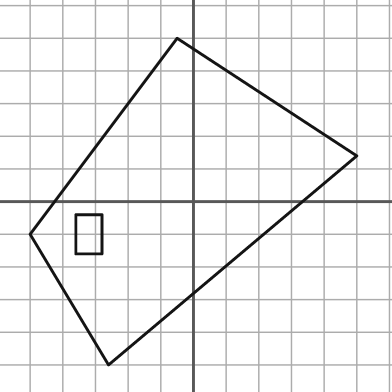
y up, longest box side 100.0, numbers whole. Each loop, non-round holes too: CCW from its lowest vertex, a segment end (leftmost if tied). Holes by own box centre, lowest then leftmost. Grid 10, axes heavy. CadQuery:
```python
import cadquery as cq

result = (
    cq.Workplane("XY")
    .moveTo(-26.0, -50.0)
    .lineTo(50.0, 14.0)
    .lineTo(-5.0, 50.0)
    .lineTo(-50.0, -10.0)
    .close()
    .moveTo(-36.0, -16.0)
    .lineTo(-28.0, -16.0)
    .lineTo(-28.0, -4.0)
    .lineTo(-36.0, -4.0)
    .close()
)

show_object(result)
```